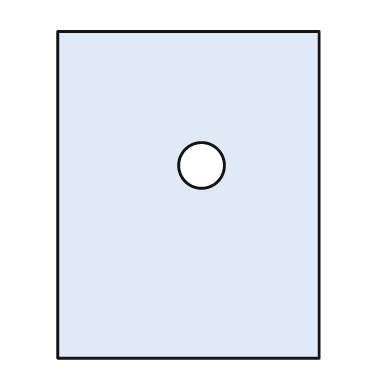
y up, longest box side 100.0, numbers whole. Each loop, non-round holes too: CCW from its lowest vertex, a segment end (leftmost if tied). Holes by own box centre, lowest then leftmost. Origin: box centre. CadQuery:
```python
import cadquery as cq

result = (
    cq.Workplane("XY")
    .moveTo(-40.0, -50.0)
    .lineTo(40.0, -50.0)
    .lineTo(40.0, 50.0)
    .lineTo(-40.0, 50.0)
    .close()
    .moveTo(4.0, 9.0)
    .circle(7.0)
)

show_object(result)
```